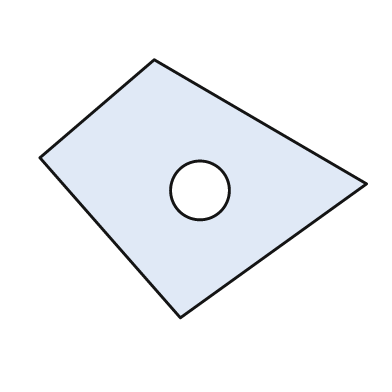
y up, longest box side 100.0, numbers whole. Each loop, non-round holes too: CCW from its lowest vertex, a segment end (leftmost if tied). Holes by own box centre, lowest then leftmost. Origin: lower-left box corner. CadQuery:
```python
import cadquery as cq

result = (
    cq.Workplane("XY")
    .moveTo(43.0, 0.0)
    .lineTo(100.0, 41.0)
    .lineTo(35.0, 79.0)
    .lineTo(0.0, 49.0)
    .close()
    .moveTo(49.0, 39.0)
    .circle(9.0)
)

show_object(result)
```